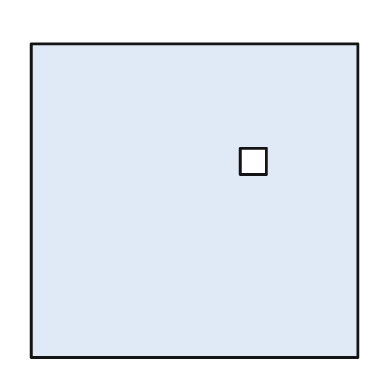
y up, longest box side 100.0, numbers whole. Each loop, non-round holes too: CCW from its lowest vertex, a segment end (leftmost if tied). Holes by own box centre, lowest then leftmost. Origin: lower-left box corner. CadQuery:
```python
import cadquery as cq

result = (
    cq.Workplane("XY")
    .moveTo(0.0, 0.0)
    .lineTo(100.0, 0.0)
    .lineTo(100.0, 96.0)
    .lineTo(0.0, 96.0)
    .close()
    .moveTo(64.0, 56.0)
    .lineTo(72.0, 56.0)
    .lineTo(72.0, 64.0)
    .lineTo(64.0, 64.0)
    .close()
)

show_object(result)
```